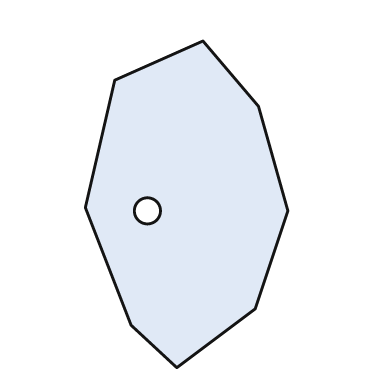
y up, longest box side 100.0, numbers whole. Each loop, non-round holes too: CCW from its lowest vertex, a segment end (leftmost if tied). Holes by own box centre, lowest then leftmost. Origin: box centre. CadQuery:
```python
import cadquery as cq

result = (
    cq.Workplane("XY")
    .moveTo(-3.0, -50.0)
    .lineTo(21.0, -32.0)
    .lineTo(31.0, -2.0)
    .lineTo(22.0, 30.0)
    .lineTo(5.0, 50.0)
    .lineTo(-22.0, 38.0)
    .lineTo(-31.0, -1.0)
    .lineTo(-17.0, -37.0)
    .close()
    .moveTo(-12.0, -2.0)
    .circle(4.0)
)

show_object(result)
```